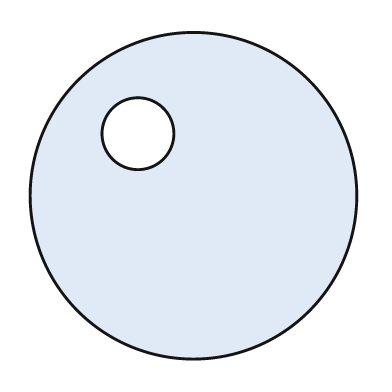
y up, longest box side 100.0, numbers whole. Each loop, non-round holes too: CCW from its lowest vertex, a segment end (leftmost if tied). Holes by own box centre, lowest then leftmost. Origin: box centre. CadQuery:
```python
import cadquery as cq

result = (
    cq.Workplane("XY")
    .moveTo(0.0, 0.0)
    .circle(50.0)
    .moveTo(-17.0, 19.0)
    .circle(11.0)
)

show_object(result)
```